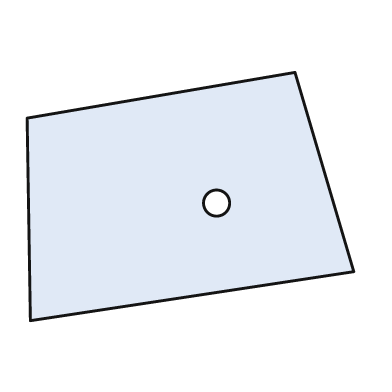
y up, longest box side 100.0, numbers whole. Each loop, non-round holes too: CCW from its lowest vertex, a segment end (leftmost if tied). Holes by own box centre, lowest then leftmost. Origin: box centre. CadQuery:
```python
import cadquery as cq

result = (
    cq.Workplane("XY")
    .moveTo(-49.0, -38.0)
    .lineTo(50.0, -23.0)
    .lineTo(32.0, 38.0)
    .lineTo(-50.0, 24.0)
    .close()
    .moveTo(8.0, -2.0)
    .circle(4.0)
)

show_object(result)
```